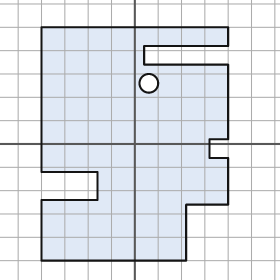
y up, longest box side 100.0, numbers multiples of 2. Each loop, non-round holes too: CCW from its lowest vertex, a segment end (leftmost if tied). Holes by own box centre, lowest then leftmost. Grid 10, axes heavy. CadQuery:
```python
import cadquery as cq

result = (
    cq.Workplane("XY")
    .moveTo(-40.0, -50.0)
    .lineTo(22.0, -50.0)
    .lineTo(22.0, -26.0)
    .lineTo(40.0, -26.0)
    .lineTo(40.0, -6.0)
    .lineTo(32.0, -6.0)
    .lineTo(32.0, 2.0)
    .lineTo(40.0, 2.0)
    .lineTo(40.0, 34.0)
    .lineTo(4.0, 34.0)
    .lineTo(4.0, 42.0)
    .lineTo(40.0, 42.0)
    .lineTo(40.0, 50.0)
    .lineTo(-40.0, 50.0)
    .lineTo(-40.0, -12.0)
    .lineTo(-16.0, -12.0)
    .lineTo(-16.0, -24.0)
    .lineTo(-40.0, -24.0)
    .close()
    .moveTo(6.0, 26.0)
    .circle(4.0)
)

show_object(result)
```